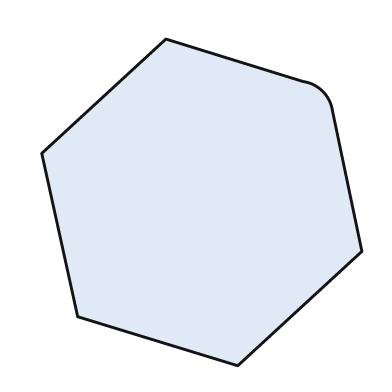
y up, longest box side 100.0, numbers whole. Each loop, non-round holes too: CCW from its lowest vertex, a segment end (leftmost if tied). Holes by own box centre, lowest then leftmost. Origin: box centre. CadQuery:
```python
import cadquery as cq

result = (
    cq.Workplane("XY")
    .moveTo(11.0, -50.0)
    .lineTo(49.0, -15.0)
    .lineTo(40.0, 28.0)
    .threePointArc((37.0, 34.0), (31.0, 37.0))
    .lineTo(-11.0, 50.0)
    .lineTo(-49.0, 15.0)
    .lineTo(-38.0, -35.0)
    .close()
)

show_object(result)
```